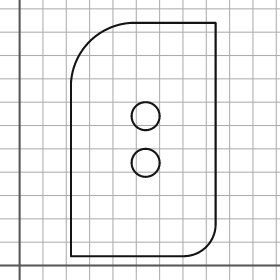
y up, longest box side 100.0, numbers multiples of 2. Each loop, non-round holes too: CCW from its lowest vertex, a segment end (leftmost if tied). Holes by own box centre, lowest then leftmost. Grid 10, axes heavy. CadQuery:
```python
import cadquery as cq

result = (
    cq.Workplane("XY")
    .moveTo(22.0, 4.0)
    .lineTo(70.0, 4.0)
    .threePointArc((80.0, 8.0), (84.0, 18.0))
    .lineTo(84.0, 104.0)
    .lineTo(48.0, 104.0)
    .threePointArc((30.0, 96.0), (22.0, 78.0))
    .close()
    .moveTo(54.0, 44.0)
    .circle(6.0)
    .moveTo(54.0, 64.0)
    .circle(6.0)
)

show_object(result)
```